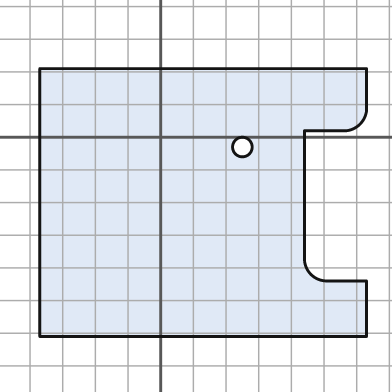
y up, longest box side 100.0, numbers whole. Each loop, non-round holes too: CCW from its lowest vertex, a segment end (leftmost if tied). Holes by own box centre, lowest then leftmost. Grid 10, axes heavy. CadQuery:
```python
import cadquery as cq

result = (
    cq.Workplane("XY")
    .moveTo(-37.0, -61.0)
    .lineTo(63.0, -61.0)
    .lineTo(63.0, -44.0)
    .lineTo(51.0, -44.0)
    .threePointArc((46.0, -42.0), (44.0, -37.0))
    .lineTo(44.0, 2.0)
    .lineTo(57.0, 2.0)
    .threePointArc((61.0, 4.0), (63.0, 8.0))
    .lineTo(63.0, 21.0)
    .lineTo(-37.0, 21.0)
    .close()
    .moveTo(25.0, -3.0)
    .circle(3.0)
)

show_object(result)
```